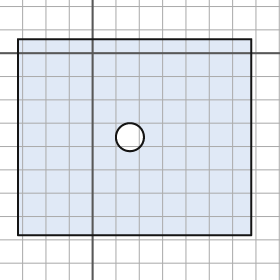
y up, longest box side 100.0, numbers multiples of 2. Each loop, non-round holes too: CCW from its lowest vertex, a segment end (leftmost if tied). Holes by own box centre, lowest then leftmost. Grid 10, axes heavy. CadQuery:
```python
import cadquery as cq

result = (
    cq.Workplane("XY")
    .moveTo(-32.0, -78.0)
    .lineTo(68.0, -78.0)
    .lineTo(68.0, 6.0)
    .lineTo(-32.0, 6.0)
    .close()
    .moveTo(16.0, -36.0)
    .circle(6.0)
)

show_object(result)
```